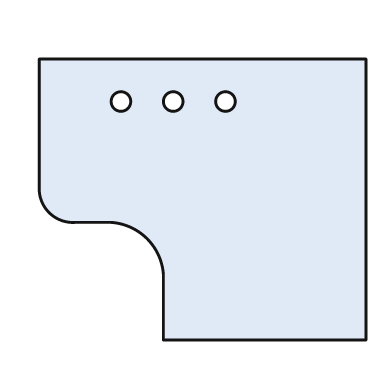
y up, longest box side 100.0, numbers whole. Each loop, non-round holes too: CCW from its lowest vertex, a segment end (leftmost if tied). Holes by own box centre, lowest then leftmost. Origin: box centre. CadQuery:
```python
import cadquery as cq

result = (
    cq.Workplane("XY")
    .moveTo(-12.0, -43.0)
    .lineTo(50.0, -43.0)
    .lineTo(50.0, 43.0)
    .lineTo(-50.0, 43.0)
    .lineTo(-50.0, 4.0)
    .threePointArc((-47.0, -4.0), (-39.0, -7.0))
    .lineTo(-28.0, -7.0)
    .threePointArc((-17.0, -12.0), (-12.0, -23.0))
    .close()
    .moveTo(-25.0, 30.0)
    .circle(3.0)
    .moveTo(-9.0, 30.0)
    .circle(3.0)
    .moveTo(7.0, 30.0)
    .circle(3.0)
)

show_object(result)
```